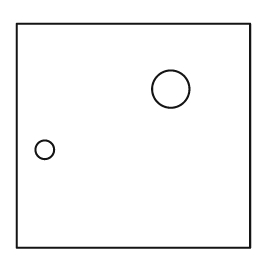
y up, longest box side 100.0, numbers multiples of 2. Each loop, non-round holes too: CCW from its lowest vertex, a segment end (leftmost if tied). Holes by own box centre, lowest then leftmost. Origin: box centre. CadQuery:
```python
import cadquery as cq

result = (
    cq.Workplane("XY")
    .moveTo(-50.0, -48.0)
    .lineTo(50.0, -48.0)
    .lineTo(50.0, 48.0)
    .lineTo(-50.0, 48.0)
    .close()
    .moveTo(-38.0, -6.0)
    .circle(4.0)
    .moveTo(16.0, 20.0)
    .circle(8.0)
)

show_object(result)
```